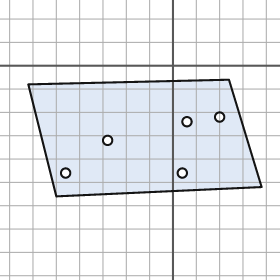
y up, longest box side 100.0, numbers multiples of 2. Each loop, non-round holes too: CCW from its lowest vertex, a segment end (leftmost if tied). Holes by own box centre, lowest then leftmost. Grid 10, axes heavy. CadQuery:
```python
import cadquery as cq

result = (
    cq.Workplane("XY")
    .moveTo(-50.0, -56.0)
    .lineTo(38.0, -52.0)
    .lineTo(24.0, -6.0)
    .lineTo(-62.0, -8.0)
    .close()
    .moveTo(-46.0, -46.0)
    .circle(2.0)
    .moveTo(4.0, -46.0)
    .circle(2.0)
    .moveTo(-28.0, -32.0)
    .circle(2.0)
    .moveTo(6.0, -24.0)
    .circle(2.0)
    .moveTo(20.0, -22.0)
    .circle(2.0)
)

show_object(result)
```